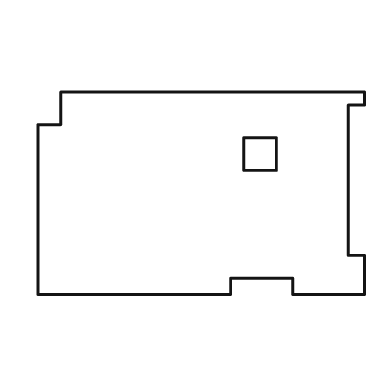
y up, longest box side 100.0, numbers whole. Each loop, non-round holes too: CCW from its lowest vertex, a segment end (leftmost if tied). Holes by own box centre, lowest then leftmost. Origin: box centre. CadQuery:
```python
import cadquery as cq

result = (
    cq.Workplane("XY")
    .moveTo(-50.0, -31.0)
    .lineTo(9.0, -31.0)
    .lineTo(9.0, -26.0)
    .lineTo(28.0, -26.0)
    .lineTo(28.0, -31.0)
    .lineTo(50.0, -31.0)
    .lineTo(50.0, -19.0)
    .lineTo(45.0, -19.0)
    .lineTo(45.0, 27.0)
    .lineTo(50.0, 27.0)
    .lineTo(50.0, 31.0)
    .lineTo(-43.0, 31.0)
    .lineTo(-43.0, 21.0)
    .lineTo(-50.0, 21.0)
    .close()
    .moveTo(13.0, 7.0)
    .lineTo(23.0, 7.0)
    .lineTo(23.0, 17.0)
    .lineTo(13.0, 17.0)
    .close()
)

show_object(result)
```